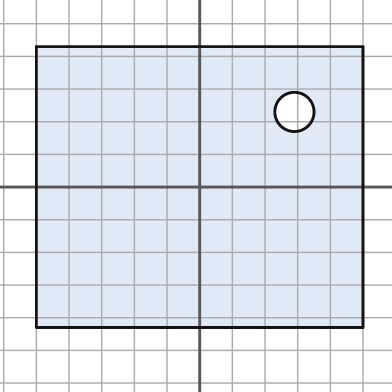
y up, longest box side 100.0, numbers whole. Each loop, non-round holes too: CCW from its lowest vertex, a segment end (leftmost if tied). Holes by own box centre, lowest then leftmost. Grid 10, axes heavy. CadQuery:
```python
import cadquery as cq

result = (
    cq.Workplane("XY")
    .moveTo(-50.0, -43.0)
    .lineTo(50.0, -43.0)
    .lineTo(50.0, 43.0)
    .lineTo(-50.0, 43.0)
    .close()
    .moveTo(29.0, 23.0)
    .circle(6.0)
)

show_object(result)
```